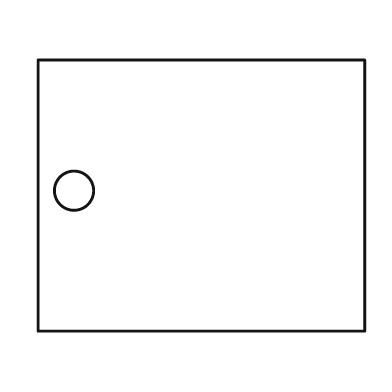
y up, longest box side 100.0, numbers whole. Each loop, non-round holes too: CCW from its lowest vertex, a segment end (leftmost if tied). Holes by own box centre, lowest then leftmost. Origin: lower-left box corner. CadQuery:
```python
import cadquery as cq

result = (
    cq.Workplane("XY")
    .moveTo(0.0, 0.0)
    .lineTo(100.0, 0.0)
    .lineTo(100.0, 83.0)
    .lineTo(0.0, 83.0)
    .close()
    .moveTo(11.0, 43.0)
    .circle(6.0)
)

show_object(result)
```